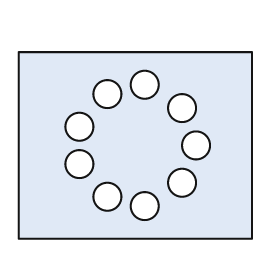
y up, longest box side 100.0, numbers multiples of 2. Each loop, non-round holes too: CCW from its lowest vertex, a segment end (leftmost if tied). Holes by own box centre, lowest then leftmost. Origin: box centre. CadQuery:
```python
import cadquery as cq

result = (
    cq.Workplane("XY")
    .moveTo(-50.0, -40.0)
    .lineTo(50.0, -40.0)
    .lineTo(50.0, 40.0)
    .lineTo(-50.0, 40.0)
    .close()
    .moveTo(4.0, -26.0)
    .circle(6.0)
    .moveTo(-12.0, -22.0)
    .circle(6.0)
    .moveTo(20.0, -16.0)
    .circle(6.0)
    .moveTo(-24.0, -8.0)
    .circle(6.0)
    .moveTo(26.0, 0.0)
    .circle(6.0)
    .moveTo(-24.0, 8.0)
    .circle(6.0)
    .moveTo(20.0, 16.0)
    .circle(6.0)
    .moveTo(-12.0, 22.0)
    .circle(6.0)
    .moveTo(4.0, 26.0)
    .circle(6.0)
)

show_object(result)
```